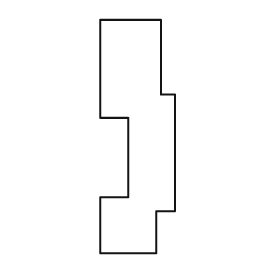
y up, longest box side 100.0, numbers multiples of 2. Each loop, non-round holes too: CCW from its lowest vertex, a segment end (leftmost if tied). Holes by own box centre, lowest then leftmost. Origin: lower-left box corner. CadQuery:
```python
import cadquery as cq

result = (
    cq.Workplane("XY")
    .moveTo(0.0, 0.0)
    .lineTo(24.0, 0.0)
    .lineTo(24.0, 18.0)
    .lineTo(32.0, 18.0)
    .lineTo(32.0, 68.0)
    .lineTo(26.0, 68.0)
    .lineTo(26.0, 100.0)
    .lineTo(0.0, 100.0)
    .lineTo(0.0, 58.0)
    .lineTo(12.0, 58.0)
    .lineTo(12.0, 24.0)
    .lineTo(0.0, 24.0)
    .close()
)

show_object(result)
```